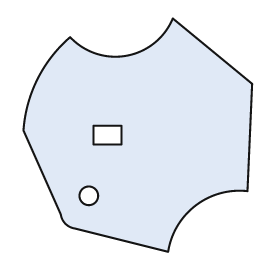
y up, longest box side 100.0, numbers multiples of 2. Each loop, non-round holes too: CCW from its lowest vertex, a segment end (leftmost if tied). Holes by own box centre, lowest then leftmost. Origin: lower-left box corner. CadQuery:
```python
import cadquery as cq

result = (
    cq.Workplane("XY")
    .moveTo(62.0, 0.0)
    .threePointArc((74.0, 20.0), (96.0, 26.0))
    .lineTo(98.0, 72.0)
    .lineTo(64.0, 100.0)
    .threePointArc((44.0, 84.0), (20.0, 92.0))
    .threePointArc((6.0, 74.0), (0.0, 52.0))
    .lineTo(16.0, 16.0)
    .threePointArc((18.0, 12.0), (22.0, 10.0))
    .close()
    .moveTo(28.0, 24.0)
    .circle(4.0)
    .moveTo(30.0, 46.0)
    .lineTo(42.0, 46.0)
    .lineTo(42.0, 54.0)
    .lineTo(30.0, 54.0)
    .close()
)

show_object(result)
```